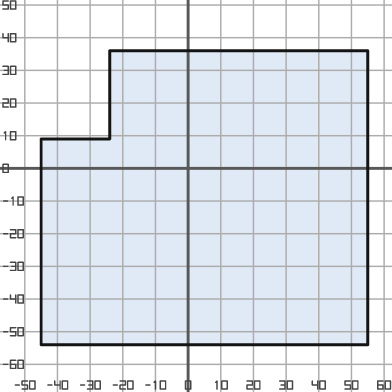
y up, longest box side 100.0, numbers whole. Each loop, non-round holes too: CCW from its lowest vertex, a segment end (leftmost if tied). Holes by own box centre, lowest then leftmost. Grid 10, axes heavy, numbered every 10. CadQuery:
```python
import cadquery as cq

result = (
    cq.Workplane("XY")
    .moveTo(-45.0, -54.0)
    .lineTo(55.0, -54.0)
    .lineTo(55.0, 36.0)
    .lineTo(-24.0, 36.0)
    .lineTo(-24.0, 9.0)
    .lineTo(-45.0, 9.0)
    .close()
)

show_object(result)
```